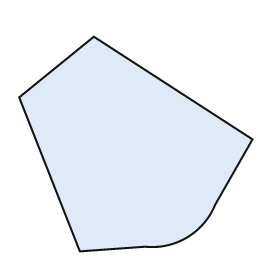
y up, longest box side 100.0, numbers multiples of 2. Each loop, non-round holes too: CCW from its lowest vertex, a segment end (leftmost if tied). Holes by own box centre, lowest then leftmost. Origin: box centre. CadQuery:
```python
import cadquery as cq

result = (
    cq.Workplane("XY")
    .moveTo(-24.0, -46.0)
    .lineTo(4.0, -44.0)
    .threePointArc((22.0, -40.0), (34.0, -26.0))
    .lineTo(50.0, 2.0)
    .lineTo(-18.0, 46.0)
    .lineTo(-50.0, 20.0)
    .close()
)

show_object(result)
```